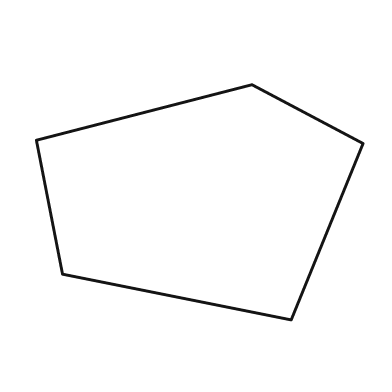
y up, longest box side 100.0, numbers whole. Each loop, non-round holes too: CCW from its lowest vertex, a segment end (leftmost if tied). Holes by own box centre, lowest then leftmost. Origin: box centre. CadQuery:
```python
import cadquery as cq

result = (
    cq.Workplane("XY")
    .moveTo(28.0, -36.0)
    .lineTo(50.0, 18.0)
    .lineTo(16.0, 36.0)
    .lineTo(-50.0, 19.0)
    .lineTo(-42.0, -22.0)
    .close()
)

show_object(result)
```